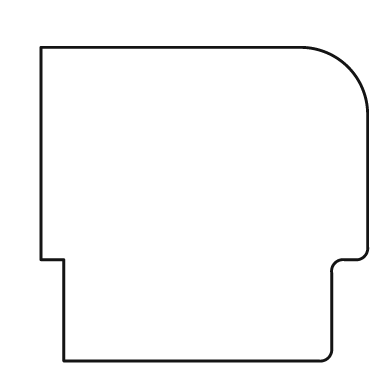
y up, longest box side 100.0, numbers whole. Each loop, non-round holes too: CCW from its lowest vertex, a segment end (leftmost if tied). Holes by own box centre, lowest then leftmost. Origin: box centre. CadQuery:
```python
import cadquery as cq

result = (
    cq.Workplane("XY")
    .moveTo(-43.0, -48.0)
    .lineTo(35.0, -48.0)
    .threePointArc((38.0, -47.0), (39.0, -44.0))
    .lineTo(39.0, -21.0)
    .threePointArc((40.0, -18.0), (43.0, -17.0))
    .lineTo(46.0, -17.0)
    .threePointArc((49.0, -16.0), (50.0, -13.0))
    .lineTo(50.0, 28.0)
    .threePointArc((44.0, 42.0), (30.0, 48.0))
    .lineTo(-50.0, 48.0)
    .lineTo(-50.0, -17.0)
    .lineTo(-43.0, -17.0)
    .close()
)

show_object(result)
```